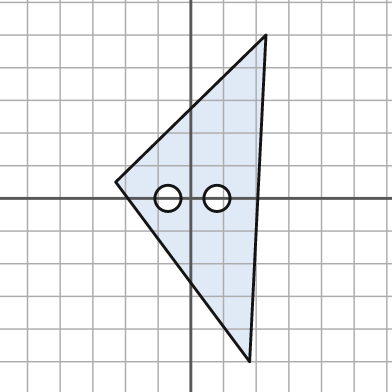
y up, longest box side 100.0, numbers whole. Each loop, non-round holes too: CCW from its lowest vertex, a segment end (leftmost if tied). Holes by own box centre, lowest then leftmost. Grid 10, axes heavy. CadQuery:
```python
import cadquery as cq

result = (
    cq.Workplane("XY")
    .moveTo(18.0, -50.0)
    .lineTo(23.0, 50.0)
    .lineTo(-23.0, 5.0)
    .close()
    .moveTo(-7.0, 0.0)
    .circle(4.0)
    .moveTo(8.0, 0.0)
    .circle(4.0)
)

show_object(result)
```